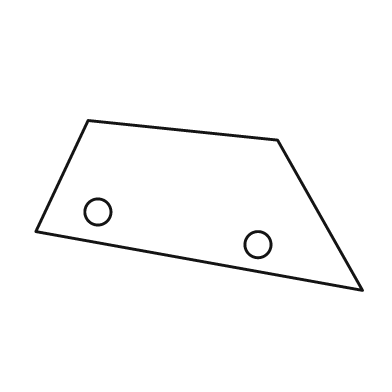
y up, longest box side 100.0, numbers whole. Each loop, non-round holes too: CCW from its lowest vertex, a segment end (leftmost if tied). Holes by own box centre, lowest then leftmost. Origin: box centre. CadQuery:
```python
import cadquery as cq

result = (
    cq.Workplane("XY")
    .moveTo(50.0, -26.0)
    .lineTo(24.0, 20.0)
    .lineTo(-34.0, 26.0)
    .lineTo(-50.0, -8.0)
    .close()
    .moveTo(18.0, -12.0)
    .circle(4.0)
    .moveTo(-31.0, -2.0)
    .circle(4.0)
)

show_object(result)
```